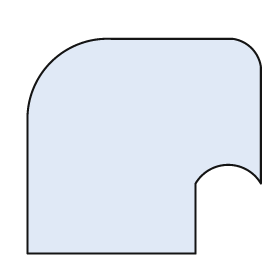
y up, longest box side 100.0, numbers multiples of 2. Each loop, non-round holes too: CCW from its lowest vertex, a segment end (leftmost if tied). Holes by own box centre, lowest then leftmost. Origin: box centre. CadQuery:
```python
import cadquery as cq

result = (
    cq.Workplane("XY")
    .moveTo(-50.0, -46.0)
    .lineTo(22.0, -46.0)
    .lineTo(22.0, -16.0)
    .threePointArc((36.0, -8.0), (50.0, -16.0))
    .lineTo(50.0, 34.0)
    .threePointArc((46.0, 42.0), (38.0, 46.0))
    .lineTo(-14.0, 46.0)
    .threePointArc((-40.0, 36.0), (-50.0, 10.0))
    .close()
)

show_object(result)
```